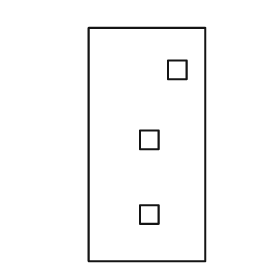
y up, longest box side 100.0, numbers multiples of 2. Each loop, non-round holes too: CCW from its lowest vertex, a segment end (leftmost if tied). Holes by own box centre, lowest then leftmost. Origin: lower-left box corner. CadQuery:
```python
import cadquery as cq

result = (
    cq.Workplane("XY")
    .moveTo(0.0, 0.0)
    .lineTo(50.0, 0.0)
    .lineTo(50.0, 100.0)
    .lineTo(0.0, 100.0)
    .close()
    .moveTo(22.0, 16.0)
    .lineTo(30.0, 16.0)
    .lineTo(30.0, 24.0)
    .lineTo(22.0, 24.0)
    .close()
    .moveTo(22.0, 48.0)
    .lineTo(30.0, 48.0)
    .lineTo(30.0, 56.0)
    .lineTo(22.0, 56.0)
    .close()
    .moveTo(34.0, 78.0)
    .lineTo(42.0, 78.0)
    .lineTo(42.0, 86.0)
    .lineTo(34.0, 86.0)
    .close()
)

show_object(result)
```